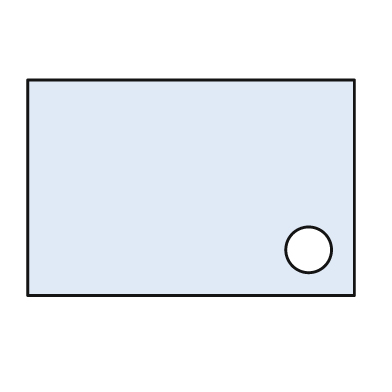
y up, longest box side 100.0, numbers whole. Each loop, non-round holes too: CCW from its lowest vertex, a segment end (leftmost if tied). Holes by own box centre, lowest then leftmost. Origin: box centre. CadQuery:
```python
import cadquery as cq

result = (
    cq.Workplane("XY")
    .moveTo(-50.0, -33.0)
    .lineTo(50.0, -33.0)
    .lineTo(50.0, 33.0)
    .lineTo(-50.0, 33.0)
    .close()
    .moveTo(36.0, -19.0)
    .circle(7.0)
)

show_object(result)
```